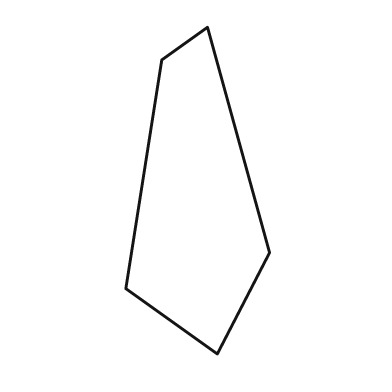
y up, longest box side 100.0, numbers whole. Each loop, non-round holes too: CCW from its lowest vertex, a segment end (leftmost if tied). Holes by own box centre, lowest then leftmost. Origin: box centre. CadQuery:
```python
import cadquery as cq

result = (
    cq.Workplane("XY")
    .moveTo(6.0, -50.0)
    .lineTo(22.0, -19.0)
    .lineTo(3.0, 50.0)
    .lineTo(-11.0, 40.0)
    .lineTo(-22.0, -30.0)
    .close()
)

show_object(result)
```